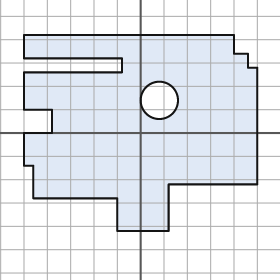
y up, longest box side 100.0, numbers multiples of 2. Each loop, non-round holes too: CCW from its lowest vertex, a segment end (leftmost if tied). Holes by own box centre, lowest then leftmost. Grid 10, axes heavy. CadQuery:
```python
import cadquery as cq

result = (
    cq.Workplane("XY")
    .moveTo(-10.0, -42.0)
    .lineTo(12.0, -42.0)
    .lineTo(12.0, -22.0)
    .lineTo(50.0, -22.0)
    .lineTo(50.0, 28.0)
    .lineTo(46.0, 28.0)
    .lineTo(46.0, 34.0)
    .lineTo(40.0, 34.0)
    .lineTo(40.0, 42.0)
    .lineTo(-50.0, 42.0)
    .lineTo(-50.0, 32.0)
    .lineTo(-8.0, 32.0)
    .lineTo(-8.0, 26.0)
    .lineTo(-50.0, 26.0)
    .lineTo(-50.0, 10.0)
    .lineTo(-38.0, 10.0)
    .lineTo(-38.0, 0.0)
    .lineTo(-50.0, 0.0)
    .lineTo(-50.0, -14.0)
    .lineTo(-46.0, -14.0)
    .lineTo(-46.0, -28.0)
    .lineTo(-10.0, -28.0)
    .close()
    .moveTo(8.0, 14.0)
    .circle(8.0)
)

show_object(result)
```